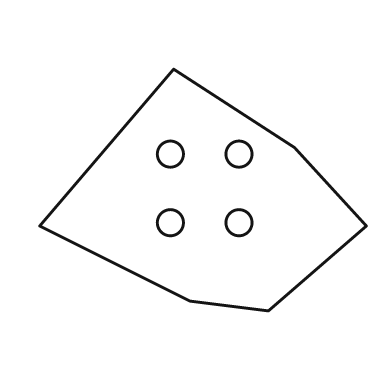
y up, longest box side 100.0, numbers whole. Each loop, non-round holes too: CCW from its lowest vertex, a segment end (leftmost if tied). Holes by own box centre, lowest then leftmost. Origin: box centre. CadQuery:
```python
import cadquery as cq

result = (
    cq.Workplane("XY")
    .moveTo(20.0, -37.0)
    .lineTo(50.0, -11.0)
    .lineTo(28.0, 13.0)
    .lineTo(-9.0, 37.0)
    .lineTo(-50.0, -11.0)
    .lineTo(-4.0, -34.0)
    .close()
    .moveTo(-10.0, -10.0)
    .circle(4.0)
    .moveTo(11.0, -10.0)
    .circle(4.0)
    .moveTo(-10.0, 11.0)
    .circle(4.0)
    .moveTo(11.0, 11.0)
    .circle(4.0)
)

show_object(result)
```